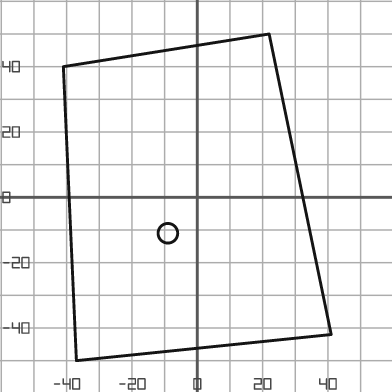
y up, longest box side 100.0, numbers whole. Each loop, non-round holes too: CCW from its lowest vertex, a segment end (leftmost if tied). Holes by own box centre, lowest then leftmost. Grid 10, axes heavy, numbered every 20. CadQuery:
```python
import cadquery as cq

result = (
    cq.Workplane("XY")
    .moveTo(-37.0, -50.0)
    .lineTo(41.0, -42.0)
    .lineTo(22.0, 50.0)
    .lineTo(-41.0, 40.0)
    .close()
    .moveTo(-9.0, -11.0)
    .circle(3.0)
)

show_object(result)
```